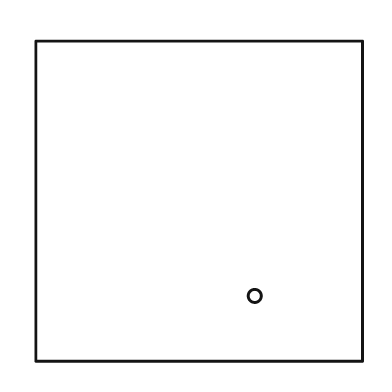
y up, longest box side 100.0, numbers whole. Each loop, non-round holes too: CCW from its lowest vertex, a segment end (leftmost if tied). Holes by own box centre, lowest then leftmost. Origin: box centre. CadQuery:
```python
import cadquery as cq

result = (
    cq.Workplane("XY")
    .moveTo(-50.0, -49.0)
    .lineTo(50.0, -49.0)
    .lineTo(50.0, 49.0)
    .lineTo(-50.0, 49.0)
    .close()
    .moveTo(17.0, -29.0)
    .circle(2.0)
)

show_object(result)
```